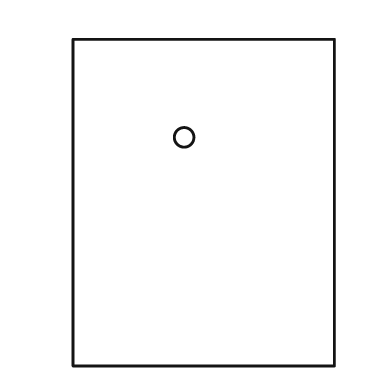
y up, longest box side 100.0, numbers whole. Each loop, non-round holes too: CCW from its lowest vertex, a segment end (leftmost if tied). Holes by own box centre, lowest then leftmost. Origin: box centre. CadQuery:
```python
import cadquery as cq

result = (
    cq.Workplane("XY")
    .moveTo(-40.0, -50.0)
    .lineTo(40.0, -50.0)
    .lineTo(40.0, 50.0)
    .lineTo(-40.0, 50.0)
    .close()
    .moveTo(-6.0, 20.0)
    .circle(3.0)
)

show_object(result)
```